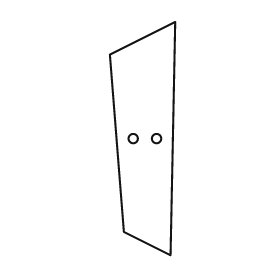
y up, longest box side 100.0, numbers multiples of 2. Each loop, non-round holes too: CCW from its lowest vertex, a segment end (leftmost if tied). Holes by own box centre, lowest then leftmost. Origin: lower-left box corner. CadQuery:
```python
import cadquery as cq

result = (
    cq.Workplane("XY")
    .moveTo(26.0, 0.0)
    .lineTo(28.0, 100.0)
    .lineTo(0.0, 86.0)
    .lineTo(6.0, 10.0)
    .close()
    .moveTo(10.0, 50.0)
    .circle(2.0)
    .moveTo(20.0, 50.0)
    .circle(2.0)
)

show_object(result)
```